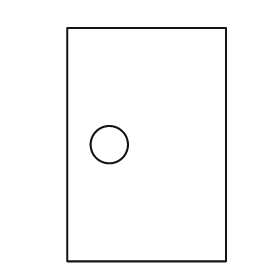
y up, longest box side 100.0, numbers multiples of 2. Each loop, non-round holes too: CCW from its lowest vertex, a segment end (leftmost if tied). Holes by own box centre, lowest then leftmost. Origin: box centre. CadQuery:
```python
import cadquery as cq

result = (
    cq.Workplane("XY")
    .moveTo(-34.0, -50.0)
    .lineTo(34.0, -50.0)
    .lineTo(34.0, 50.0)
    .lineTo(-34.0, 50.0)
    .close()
    .moveTo(-16.0, 0.0)
    .circle(8.0)
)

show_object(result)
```